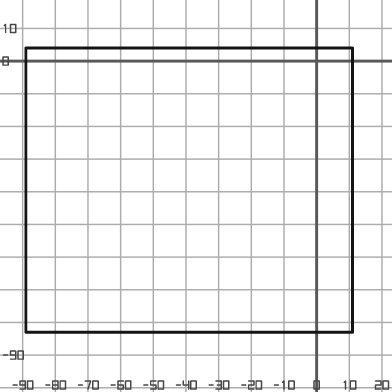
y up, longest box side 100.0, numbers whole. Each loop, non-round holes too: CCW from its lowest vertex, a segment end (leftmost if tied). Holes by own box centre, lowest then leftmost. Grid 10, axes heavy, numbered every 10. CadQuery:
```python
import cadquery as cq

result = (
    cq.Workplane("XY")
    .moveTo(-89.0, -83.0)
    .lineTo(11.0, -83.0)
    .lineTo(11.0, 4.0)
    .lineTo(-89.0, 4.0)
    .close()
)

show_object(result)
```